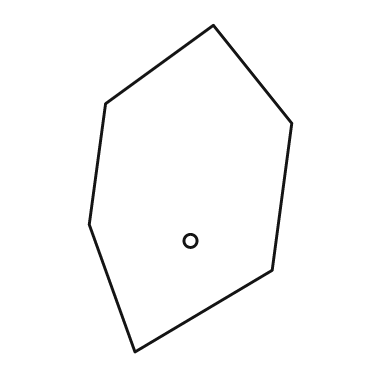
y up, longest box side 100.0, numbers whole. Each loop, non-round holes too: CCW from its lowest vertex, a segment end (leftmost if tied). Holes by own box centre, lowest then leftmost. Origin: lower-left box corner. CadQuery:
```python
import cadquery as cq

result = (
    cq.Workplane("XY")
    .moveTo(14.0, 0.0)
    .lineTo(56.0, 25.0)
    .lineTo(62.0, 70.0)
    .lineTo(38.0, 100.0)
    .lineTo(5.0, 76.0)
    .lineTo(0.0, 39.0)
    .close()
    .moveTo(31.0, 34.0)
    .circle(2.0)
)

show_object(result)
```